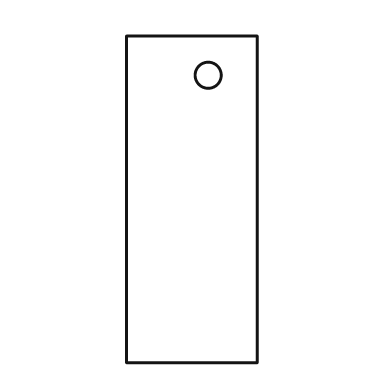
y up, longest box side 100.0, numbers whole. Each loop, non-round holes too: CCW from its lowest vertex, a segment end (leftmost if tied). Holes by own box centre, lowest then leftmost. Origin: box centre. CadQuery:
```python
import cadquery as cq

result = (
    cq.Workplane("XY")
    .moveTo(-20.0, -50.0)
    .lineTo(20.0, -50.0)
    .lineTo(20.0, 50.0)
    .lineTo(-20.0, 50.0)
    .close()
    .moveTo(5.0, 38.0)
    .circle(4.0)
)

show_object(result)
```